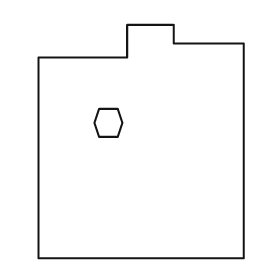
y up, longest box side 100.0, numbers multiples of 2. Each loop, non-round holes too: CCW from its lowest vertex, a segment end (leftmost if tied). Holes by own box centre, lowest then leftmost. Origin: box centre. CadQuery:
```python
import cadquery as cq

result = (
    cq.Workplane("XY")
    .moveTo(-44.0, -50.0)
    .lineTo(44.0, -50.0)
    .lineTo(44.0, 42.0)
    .lineTo(14.0, 42.0)
    .lineTo(14.0, 50.0)
    .lineTo(-6.0, 50.0)
    .lineTo(-6.0, 36.0)
    .lineTo(-44.0, 36.0)
    .close()
    .moveTo(-18.0, 2.0)
    .lineTo(-10.0, 2.0)
    .lineTo(-8.0, 8.0)
    .lineTo(-10.0, 14.0)
    .lineTo(-18.0, 14.0)
    .lineTo(-20.0, 8.0)
    .close()
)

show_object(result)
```